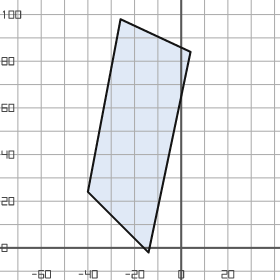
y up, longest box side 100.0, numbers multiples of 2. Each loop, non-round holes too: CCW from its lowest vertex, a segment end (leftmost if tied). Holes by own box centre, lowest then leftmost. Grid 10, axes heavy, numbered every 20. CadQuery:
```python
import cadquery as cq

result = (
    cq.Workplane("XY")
    .moveTo(-14.0, -2.0)
    .lineTo(4.0, 84.0)
    .lineTo(-26.0, 98.0)
    .lineTo(-40.0, 24.0)
    .close()
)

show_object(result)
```